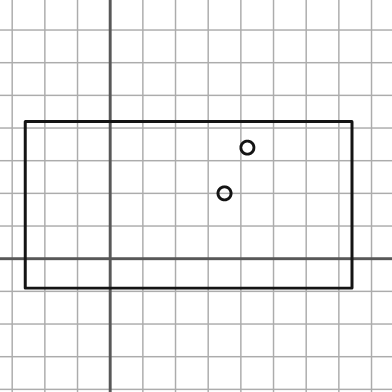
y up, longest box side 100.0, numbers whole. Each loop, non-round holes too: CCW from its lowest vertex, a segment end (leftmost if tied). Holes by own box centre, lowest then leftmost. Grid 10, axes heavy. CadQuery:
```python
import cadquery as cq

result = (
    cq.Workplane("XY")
    .moveTo(-26.0, -9.0)
    .lineTo(74.0, -9.0)
    .lineTo(74.0, 42.0)
    .lineTo(-26.0, 42.0)
    .close()
    .moveTo(35.0, 20.0)
    .circle(2.0)
    .moveTo(42.0, 34.0)
    .circle(2.0)
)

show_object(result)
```